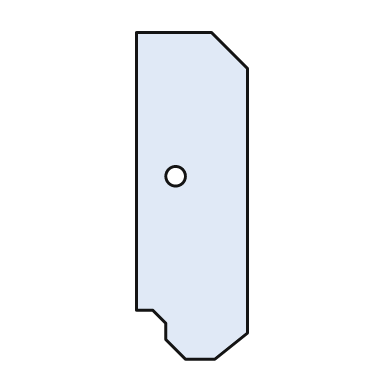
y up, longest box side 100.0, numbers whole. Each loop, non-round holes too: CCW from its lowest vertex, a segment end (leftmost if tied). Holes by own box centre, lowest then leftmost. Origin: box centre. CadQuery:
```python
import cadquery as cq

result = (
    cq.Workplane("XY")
    .moveTo(-2.0, -50.0)
    .lineTo(7.0, -50.0)
    .lineTo(17.0, -42.0)
    .lineTo(17.0, 39.0)
    .lineTo(6.0, 50.0)
    .lineTo(-17.0, 50.0)
    .lineTo(-17.0, -35.0)
    .lineTo(-12.0, -35.0)
    .lineTo(-8.0, -39.0)
    .lineTo(-8.0, -44.0)
    .close()
    .moveTo(-5.0, 6.0)
    .circle(3.0)
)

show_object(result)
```